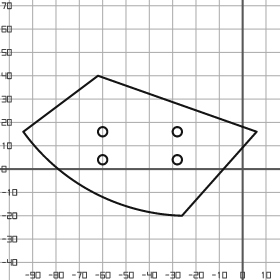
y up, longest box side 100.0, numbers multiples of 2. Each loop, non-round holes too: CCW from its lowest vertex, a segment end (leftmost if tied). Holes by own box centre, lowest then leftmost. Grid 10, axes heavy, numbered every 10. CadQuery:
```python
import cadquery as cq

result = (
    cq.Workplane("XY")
    .moveTo(-26.0, -20.0)
    .lineTo(6.0, 16.0)
    .lineTo(-62.0, 40.0)
    .lineTo(-94.0, 16.0)
    .threePointArc((-64.0, -10.0), (-26.0, -20.0))
    .close()
    .moveTo(-60.0, 4.0)
    .circle(2.0)
    .moveTo(-28.0, 4.0)
    .circle(2.0)
    .moveTo(-60.0, 16.0)
    .circle(2.0)
    .moveTo(-28.0, 16.0)
    .circle(2.0)
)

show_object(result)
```